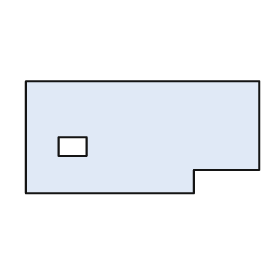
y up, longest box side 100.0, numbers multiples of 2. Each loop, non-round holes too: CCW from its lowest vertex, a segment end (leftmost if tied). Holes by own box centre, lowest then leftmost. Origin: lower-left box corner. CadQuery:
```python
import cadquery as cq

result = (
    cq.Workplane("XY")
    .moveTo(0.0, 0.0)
    .lineTo(72.0, 0.0)
    .lineTo(72.0, 10.0)
    .lineTo(100.0, 10.0)
    .lineTo(100.0, 48.0)
    .lineTo(0.0, 48.0)
    .close()
    .moveTo(14.0, 16.0)
    .lineTo(26.0, 16.0)
    .lineTo(26.0, 24.0)
    .lineTo(14.0, 24.0)
    .close()
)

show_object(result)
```